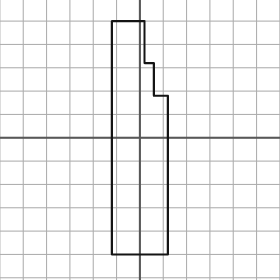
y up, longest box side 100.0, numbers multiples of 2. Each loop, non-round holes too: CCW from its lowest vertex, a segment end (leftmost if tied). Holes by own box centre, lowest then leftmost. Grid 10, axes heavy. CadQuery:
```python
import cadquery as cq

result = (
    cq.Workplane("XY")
    .moveTo(-12.0, -50.0)
    .lineTo(12.0, -50.0)
    .lineTo(12.0, 18.0)
    .lineTo(6.0, 18.0)
    .lineTo(6.0, 32.0)
    .lineTo(2.0, 32.0)
    .lineTo(2.0, 50.0)
    .lineTo(-12.0, 50.0)
    .close()
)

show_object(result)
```